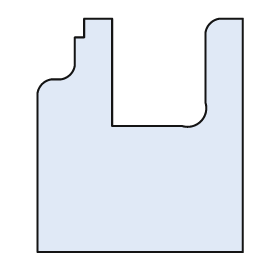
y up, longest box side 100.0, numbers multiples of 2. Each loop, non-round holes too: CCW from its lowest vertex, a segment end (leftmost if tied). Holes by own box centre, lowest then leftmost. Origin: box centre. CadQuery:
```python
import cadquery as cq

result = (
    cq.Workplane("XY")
    .moveTo(-44.0, -50.0)
    .lineTo(44.0, -50.0)
    .lineTo(44.0, 50.0)
    .lineTo(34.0, 50.0)
    .threePointArc((30.0, 48.0), (28.0, 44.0))
    .lineTo(28.0, 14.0)
    .threePointArc((26.0, 6.0), (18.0, 4.0))
    .lineTo(-12.0, 4.0)
    .lineTo(-12.0, 50.0)
    .lineTo(-24.0, 50.0)
    .lineTo(-24.0, 42.0)
    .lineTo(-28.0, 42.0)
    .lineTo(-28.0, 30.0)
    .threePointArc((-30.0, 26.0), (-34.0, 24.0))
    .lineTo(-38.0, 24.0)
    .threePointArc((-42.0, 22.0), (-44.0, 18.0))
    .close()
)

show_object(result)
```